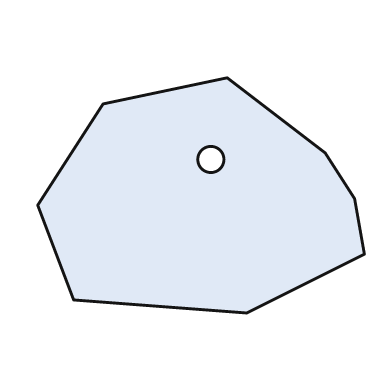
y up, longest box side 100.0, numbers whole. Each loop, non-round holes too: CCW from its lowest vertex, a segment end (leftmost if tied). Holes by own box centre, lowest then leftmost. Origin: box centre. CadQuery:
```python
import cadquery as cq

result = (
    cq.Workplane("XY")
    .moveTo(14.0, -36.0)
    .lineTo(50.0, -18.0)
    .lineTo(47.0, -1.0)
    .lineTo(38.0, 13.0)
    .lineTo(8.0, 36.0)
    .lineTo(-30.0, 28.0)
    .lineTo(-50.0, -3.0)
    .lineTo(-39.0, -32.0)
    .close()
    .moveTo(3.0, 11.0)
    .circle(4.0)
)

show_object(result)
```